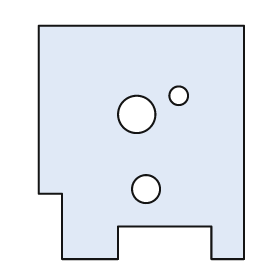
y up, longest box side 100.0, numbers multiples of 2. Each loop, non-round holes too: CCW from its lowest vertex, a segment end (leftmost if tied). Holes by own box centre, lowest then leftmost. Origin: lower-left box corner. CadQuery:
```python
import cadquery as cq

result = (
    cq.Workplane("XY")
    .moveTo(10.0, 0.0)
    .lineTo(34.0, 0.0)
    .lineTo(34.0, 14.0)
    .lineTo(74.0, 14.0)
    .lineTo(74.0, 0.0)
    .lineTo(88.0, 0.0)
    .lineTo(88.0, 100.0)
    .lineTo(0.0, 100.0)
    .lineTo(0.0, 28.0)
    .lineTo(10.0, 28.0)
    .close()
    .moveTo(46.0, 30.0)
    .circle(6.0)
    .moveTo(42.0, 62.0)
    .circle(8.0)
    .moveTo(60.0, 70.0)
    .circle(4.0)
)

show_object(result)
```